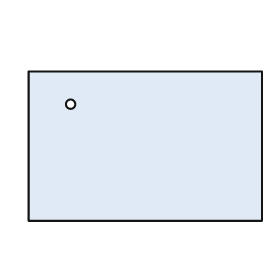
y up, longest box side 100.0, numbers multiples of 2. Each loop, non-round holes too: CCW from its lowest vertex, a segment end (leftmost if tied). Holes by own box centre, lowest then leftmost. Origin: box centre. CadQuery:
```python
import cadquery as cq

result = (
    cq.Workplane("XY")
    .moveTo(-50.0, -32.0)
    .lineTo(50.0, -32.0)
    .lineTo(50.0, 32.0)
    .lineTo(-50.0, 32.0)
    .close()
    .moveTo(-32.0, 18.0)
    .circle(2.0)
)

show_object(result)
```